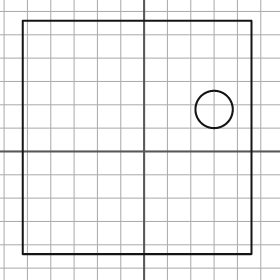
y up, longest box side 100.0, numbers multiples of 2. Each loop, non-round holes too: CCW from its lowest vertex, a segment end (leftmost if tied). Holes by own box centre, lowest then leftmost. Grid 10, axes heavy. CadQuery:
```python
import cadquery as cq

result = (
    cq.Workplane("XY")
    .moveTo(-52.0, -44.0)
    .lineTo(46.0, -44.0)
    .lineTo(46.0, 56.0)
    .lineTo(-52.0, 56.0)
    .close()
    .moveTo(30.0, 18.0)
    .circle(8.0)
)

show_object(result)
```